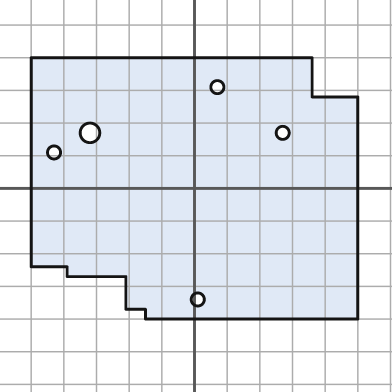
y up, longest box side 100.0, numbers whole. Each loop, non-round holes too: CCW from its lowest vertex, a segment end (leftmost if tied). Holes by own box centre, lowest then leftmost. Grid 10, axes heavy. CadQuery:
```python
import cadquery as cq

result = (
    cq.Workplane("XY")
    .moveTo(-15.0, -40.0)
    .lineTo(50.0, -40.0)
    .lineTo(50.0, 28.0)
    .lineTo(36.0, 28.0)
    .lineTo(36.0, 40.0)
    .lineTo(-50.0, 40.0)
    .lineTo(-50.0, -24.0)
    .lineTo(-39.0, -24.0)
    .lineTo(-39.0, -27.0)
    .lineTo(-21.0, -27.0)
    .lineTo(-21.0, -37.0)
    .lineTo(-15.0, -37.0)
    .close()
    .moveTo(1.0, -34.0)
    .circle(2.0)
    .moveTo(-43.0, 11.0)
    .circle(2.0)
    .moveTo(-32.0, 17.0)
    .circle(3.0)
    .moveTo(27.0, 17.0)
    .circle(2.0)
    .moveTo(7.0, 31.0)
    .circle(2.0)
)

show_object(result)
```